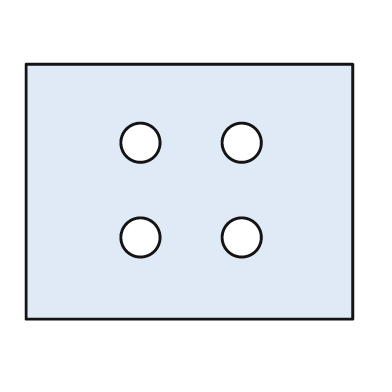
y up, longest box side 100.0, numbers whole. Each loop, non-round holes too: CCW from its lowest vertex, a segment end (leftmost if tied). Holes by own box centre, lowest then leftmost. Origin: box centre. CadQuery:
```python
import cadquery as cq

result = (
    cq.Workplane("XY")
    .moveTo(-50.0, -39.0)
    .lineTo(50.0, -39.0)
    .lineTo(50.0, 39.0)
    .lineTo(-50.0, 39.0)
    .close()
    .moveTo(-15.0, -14.0)
    .circle(6.0)
    .moveTo(16.0, -14.0)
    .circle(6.0)
    .moveTo(-15.0, 15.0)
    .circle(6.0)
    .moveTo(16.0, 15.0)
    .circle(6.0)
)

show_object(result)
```